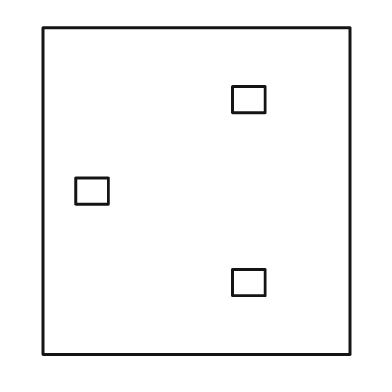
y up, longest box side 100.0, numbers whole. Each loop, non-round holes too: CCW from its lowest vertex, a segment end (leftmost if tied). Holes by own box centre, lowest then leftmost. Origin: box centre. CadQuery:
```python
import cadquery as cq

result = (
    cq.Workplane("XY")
    .moveTo(-47.0, -50.0)
    .lineTo(47.0, -50.0)
    .lineTo(47.0, 50.0)
    .lineTo(-47.0, 50.0)
    .close()
    .moveTo(11.0, -32.0)
    .lineTo(21.0, -32.0)
    .lineTo(21.0, -24.0)
    .lineTo(11.0, -24.0)
    .close()
    .moveTo(-37.0, -4.0)
    .lineTo(-27.0, -4.0)
    .lineTo(-27.0, 4.0)
    .lineTo(-37.0, 4.0)
    .close()
    .moveTo(11.0, 24.0)
    .lineTo(21.0, 24.0)
    .lineTo(21.0, 32.0)
    .lineTo(11.0, 32.0)
    .close()
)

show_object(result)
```